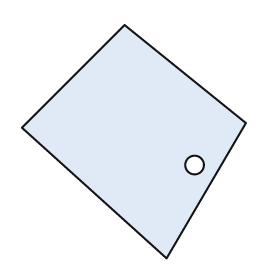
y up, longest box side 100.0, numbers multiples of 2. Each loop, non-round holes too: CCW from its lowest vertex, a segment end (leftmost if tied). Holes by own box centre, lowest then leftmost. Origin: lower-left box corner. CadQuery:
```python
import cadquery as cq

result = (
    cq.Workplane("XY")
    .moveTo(62.0, 0.0)
    .lineTo(96.0, 58.0)
    .lineTo(44.0, 100.0)
    .lineTo(0.0, 56.0)
    .close()
    .moveTo(74.0, 40.0)
    .circle(4.0)
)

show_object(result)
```